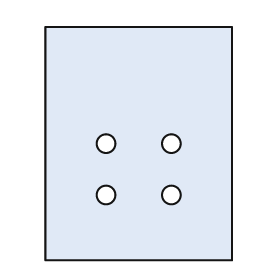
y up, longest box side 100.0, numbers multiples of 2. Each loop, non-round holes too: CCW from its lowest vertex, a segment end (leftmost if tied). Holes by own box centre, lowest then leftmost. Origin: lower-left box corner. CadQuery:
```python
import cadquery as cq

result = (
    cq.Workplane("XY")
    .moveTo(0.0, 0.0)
    .lineTo(80.0, 0.0)
    .lineTo(80.0, 100.0)
    .lineTo(0.0, 100.0)
    .close()
    .moveTo(26.0, 28.0)
    .circle(4.0)
    .moveTo(54.0, 28.0)
    .circle(4.0)
    .moveTo(26.0, 50.0)
    .circle(4.0)
    .moveTo(54.0, 50.0)
    .circle(4.0)
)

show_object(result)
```